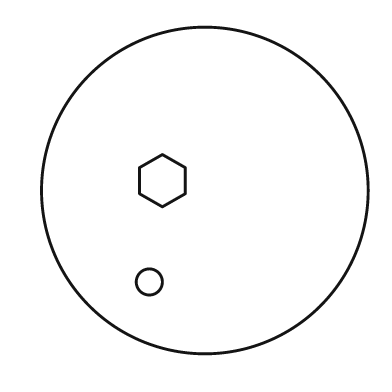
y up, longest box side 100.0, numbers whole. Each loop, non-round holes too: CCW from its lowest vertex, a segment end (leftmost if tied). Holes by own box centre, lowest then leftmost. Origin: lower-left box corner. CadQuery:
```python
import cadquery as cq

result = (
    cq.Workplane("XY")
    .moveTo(50.0, 50.0)
    .circle(50.0)
    .moveTo(33.0, 22.0)
    .circle(4.0)
    .moveTo(37.0, 45.0)
    .lineTo(44.0, 49.0)
    .lineTo(44.0, 57.0)
    .lineTo(37.0, 61.0)
    .lineTo(30.0, 57.0)
    .lineTo(30.0, 49.0)
    .close()
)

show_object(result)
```